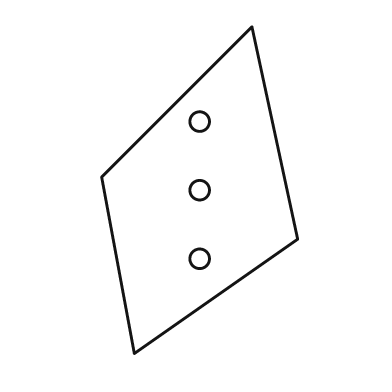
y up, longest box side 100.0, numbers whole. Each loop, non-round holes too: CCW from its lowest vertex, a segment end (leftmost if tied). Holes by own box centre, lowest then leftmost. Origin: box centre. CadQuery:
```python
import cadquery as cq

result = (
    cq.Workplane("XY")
    .moveTo(-20.0, -50.0)
    .lineTo(30.0, -15.0)
    .lineTo(16.0, 50.0)
    .lineTo(-30.0, 4.0)
    .close()
    .moveTo(0.0, -21.0)
    .circle(3.0)
    .moveTo(0.0, 0.0)
    .circle(3.0)
    .moveTo(0.0, 21.0)
    .circle(3.0)
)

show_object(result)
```